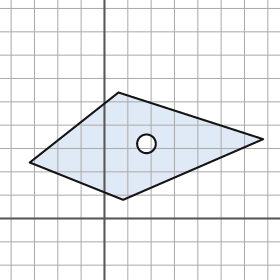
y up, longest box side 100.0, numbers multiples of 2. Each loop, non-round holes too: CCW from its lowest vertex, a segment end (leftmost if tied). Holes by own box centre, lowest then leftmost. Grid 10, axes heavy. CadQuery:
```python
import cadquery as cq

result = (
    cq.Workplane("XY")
    .moveTo(8.0, 8.0)
    .lineTo(68.0, 34.0)
    .lineTo(6.0, 54.0)
    .lineTo(-32.0, 24.0)
    .close()
    .moveTo(18.0, 32.0)
    .circle(4.0)
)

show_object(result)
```